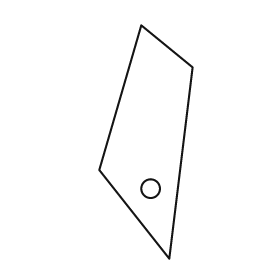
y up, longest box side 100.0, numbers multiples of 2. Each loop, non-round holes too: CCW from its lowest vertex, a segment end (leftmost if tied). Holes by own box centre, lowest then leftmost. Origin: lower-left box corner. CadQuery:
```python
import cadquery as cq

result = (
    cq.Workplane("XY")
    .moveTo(30.0, 0.0)
    .lineTo(40.0, 82.0)
    .lineTo(18.0, 100.0)
    .lineTo(0.0, 38.0)
    .close()
    .moveTo(22.0, 30.0)
    .circle(4.0)
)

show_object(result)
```